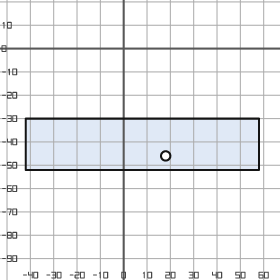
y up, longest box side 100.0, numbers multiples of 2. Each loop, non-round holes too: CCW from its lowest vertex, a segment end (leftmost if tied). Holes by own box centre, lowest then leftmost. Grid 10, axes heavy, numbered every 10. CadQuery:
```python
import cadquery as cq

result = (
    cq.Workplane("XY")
    .moveTo(-42.0, -52.0)
    .lineTo(58.0, -52.0)
    .lineTo(58.0, -30.0)
    .lineTo(-42.0, -30.0)
    .close()
    .moveTo(18.0, -46.0)
    .circle(2.0)
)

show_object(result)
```